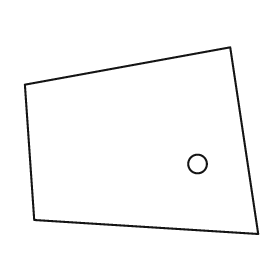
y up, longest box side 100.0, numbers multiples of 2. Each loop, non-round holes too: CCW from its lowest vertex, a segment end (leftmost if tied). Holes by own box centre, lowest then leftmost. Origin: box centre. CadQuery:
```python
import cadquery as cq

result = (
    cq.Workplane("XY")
    .moveTo(50.0, -40.0)
    .lineTo(38.0, 40.0)
    .lineTo(-50.0, 24.0)
    .lineTo(-46.0, -34.0)
    .close()
    .moveTo(24.0, -10.0)
    .circle(4.0)
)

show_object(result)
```